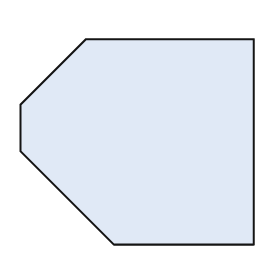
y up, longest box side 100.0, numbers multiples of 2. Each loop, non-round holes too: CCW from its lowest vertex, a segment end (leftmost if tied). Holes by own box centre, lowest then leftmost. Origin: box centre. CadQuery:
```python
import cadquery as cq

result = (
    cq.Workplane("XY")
    .moveTo(-10.0, -44.0)
    .lineTo(50.0, -44.0)
    .lineTo(50.0, 44.0)
    .lineTo(-22.0, 44.0)
    .lineTo(-50.0, 16.0)
    .lineTo(-50.0, -4.0)
    .close()
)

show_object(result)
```